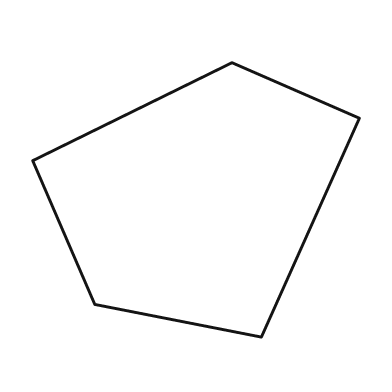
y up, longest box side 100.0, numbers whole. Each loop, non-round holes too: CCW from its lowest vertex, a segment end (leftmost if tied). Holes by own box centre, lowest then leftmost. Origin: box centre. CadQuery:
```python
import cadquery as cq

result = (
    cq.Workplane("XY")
    .moveTo(20.0, -42.0)
    .lineTo(50.0, 25.0)
    .lineTo(11.0, 42.0)
    .lineTo(-50.0, 12.0)
    .lineTo(-31.0, -32.0)
    .close()
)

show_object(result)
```